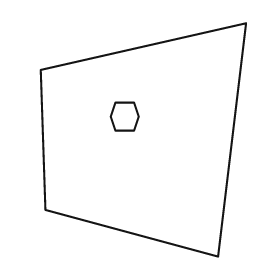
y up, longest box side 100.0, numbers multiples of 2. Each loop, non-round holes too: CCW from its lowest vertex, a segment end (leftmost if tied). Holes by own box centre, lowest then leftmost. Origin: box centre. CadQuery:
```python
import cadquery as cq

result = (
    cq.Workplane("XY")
    .moveTo(32.0, -50.0)
    .lineTo(44.0, 50.0)
    .lineTo(-44.0, 30.0)
    .lineTo(-42.0, -30.0)
    .close()
    .moveTo(-12.0, 4.0)
    .lineTo(-4.0, 4.0)
    .lineTo(-2.0, 10.0)
    .lineTo(-4.0, 16.0)
    .lineTo(-12.0, 16.0)
    .lineTo(-14.0, 10.0)
    .close()
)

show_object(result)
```